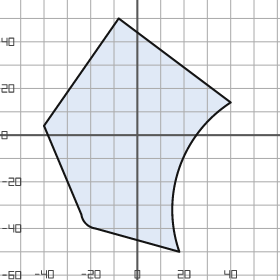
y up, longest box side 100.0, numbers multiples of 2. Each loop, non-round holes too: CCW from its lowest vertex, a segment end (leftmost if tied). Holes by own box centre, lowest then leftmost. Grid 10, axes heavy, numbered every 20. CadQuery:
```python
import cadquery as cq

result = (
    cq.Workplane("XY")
    .moveTo(18.0, -50.0)
    .threePointArc((18.0, -14.0), (40.0, 14.0))
    .lineTo(-8.0, 50.0)
    .lineTo(-40.0, 4.0)
    .lineTo(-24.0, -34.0)
    .threePointArc((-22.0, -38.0), (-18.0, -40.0))
    .close()
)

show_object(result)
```